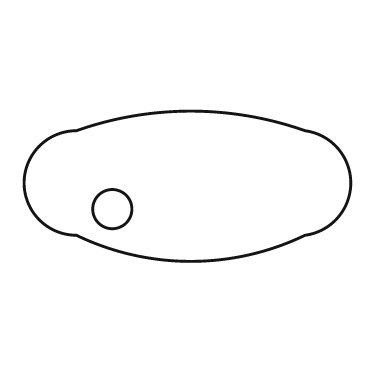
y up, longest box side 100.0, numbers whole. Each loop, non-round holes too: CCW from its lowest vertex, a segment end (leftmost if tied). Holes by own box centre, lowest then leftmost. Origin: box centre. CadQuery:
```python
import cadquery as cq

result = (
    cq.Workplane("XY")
    .moveTo(-34.0, -15.0)
    .threePointArc((1.0, -23.0), (36.0, -15.0))
    .threePointArc((50.0, 1.0), (36.0, 17.0))
    .threePointArc((1.0, 23.0), (-34.0, 17.0))
    .threePointArc((-50.0, 1.0), (-34.0, -15.0))
    .close()
    .moveTo(-23.0, -7.0)
    .circle(6.0)
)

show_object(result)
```